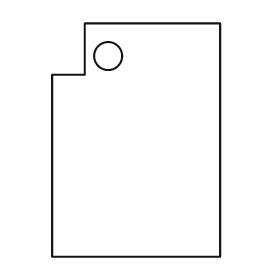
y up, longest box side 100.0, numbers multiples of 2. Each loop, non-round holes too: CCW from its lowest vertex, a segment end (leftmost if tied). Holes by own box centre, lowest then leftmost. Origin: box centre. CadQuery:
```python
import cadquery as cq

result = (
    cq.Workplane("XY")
    .moveTo(-36.0, -50.0)
    .lineTo(36.0, -50.0)
    .lineTo(36.0, 50.0)
    .lineTo(-22.0, 50.0)
    .lineTo(-22.0, 28.0)
    .lineTo(-36.0, 28.0)
    .close()
    .moveTo(-12.0, 36.0)
    .circle(6.0)
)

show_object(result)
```